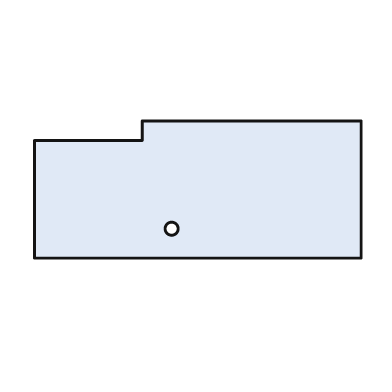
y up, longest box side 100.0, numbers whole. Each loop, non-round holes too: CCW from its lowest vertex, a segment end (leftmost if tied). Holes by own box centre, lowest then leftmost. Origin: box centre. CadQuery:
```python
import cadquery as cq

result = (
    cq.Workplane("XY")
    .moveTo(-50.0, -21.0)
    .lineTo(50.0, -21.0)
    .lineTo(50.0, 21.0)
    .lineTo(-17.0, 21.0)
    .lineTo(-17.0, 15.0)
    .lineTo(-50.0, 15.0)
    .close()
    .moveTo(-8.0, -12.0)
    .circle(2.0)
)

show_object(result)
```